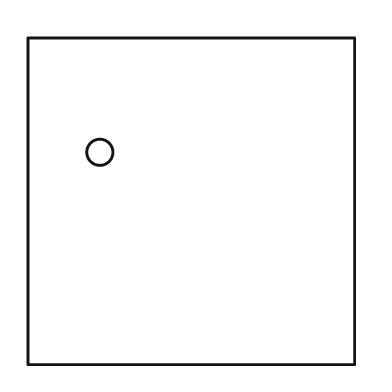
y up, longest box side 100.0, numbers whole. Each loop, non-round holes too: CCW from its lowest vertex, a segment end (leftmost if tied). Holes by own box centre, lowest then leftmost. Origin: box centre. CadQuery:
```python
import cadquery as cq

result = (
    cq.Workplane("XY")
    .moveTo(-50.0, -50.0)
    .lineTo(50.0, -50.0)
    .lineTo(50.0, 50.0)
    .lineTo(-50.0, 50.0)
    .close()
    .moveTo(-28.0, 15.0)
    .circle(4.0)
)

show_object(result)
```